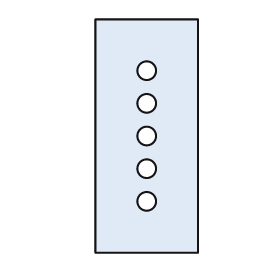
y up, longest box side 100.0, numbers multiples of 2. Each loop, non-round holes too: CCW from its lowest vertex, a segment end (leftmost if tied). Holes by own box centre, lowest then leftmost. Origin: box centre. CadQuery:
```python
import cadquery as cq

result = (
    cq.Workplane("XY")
    .moveTo(-22.0, -50.0)
    .lineTo(22.0, -50.0)
    .lineTo(22.0, 50.0)
    .lineTo(-22.0, 50.0)
    .close()
    .moveTo(0.0, -28.0)
    .circle(4.0)
    .moveTo(0.0, -14.0)
    .circle(4.0)
    .moveTo(0.0, 0.0)
    .circle(4.0)
    .moveTo(0.0, 14.0)
    .circle(4.0)
    .moveTo(0.0, 28.0)
    .circle(4.0)
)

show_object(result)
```